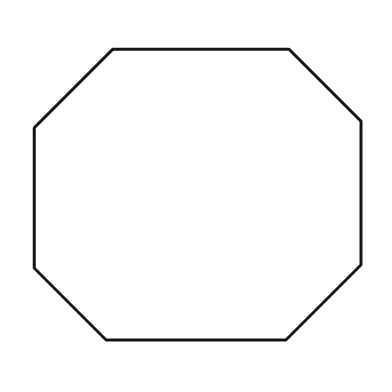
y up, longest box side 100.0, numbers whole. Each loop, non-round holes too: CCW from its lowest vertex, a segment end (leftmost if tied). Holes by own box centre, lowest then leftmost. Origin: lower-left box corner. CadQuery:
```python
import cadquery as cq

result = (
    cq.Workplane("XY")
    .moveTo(22.0, 0.0)
    .lineTo(77.0, 0.0)
    .lineTo(100.0, 23.0)
    .lineTo(100.0, 67.0)
    .lineTo(78.0, 89.0)
    .lineTo(24.0, 89.0)
    .lineTo(0.0, 65.0)
    .lineTo(0.0, 22.0)
    .close()
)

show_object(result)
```